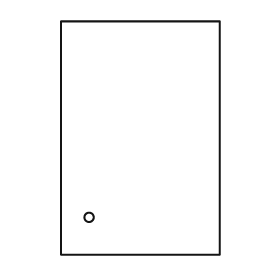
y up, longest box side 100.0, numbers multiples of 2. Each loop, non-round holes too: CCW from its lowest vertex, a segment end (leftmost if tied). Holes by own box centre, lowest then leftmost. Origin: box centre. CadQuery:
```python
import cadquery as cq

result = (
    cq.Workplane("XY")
    .moveTo(-34.0, -50.0)
    .lineTo(34.0, -50.0)
    .lineTo(34.0, 50.0)
    .lineTo(-34.0, 50.0)
    .close()
    .moveTo(-22.0, -34.0)
    .circle(2.0)
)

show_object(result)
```